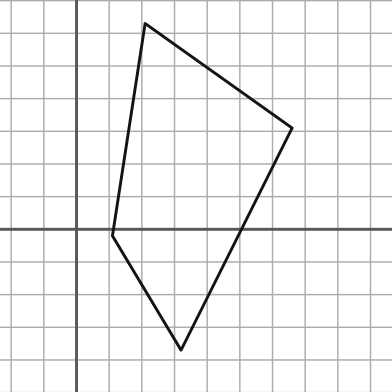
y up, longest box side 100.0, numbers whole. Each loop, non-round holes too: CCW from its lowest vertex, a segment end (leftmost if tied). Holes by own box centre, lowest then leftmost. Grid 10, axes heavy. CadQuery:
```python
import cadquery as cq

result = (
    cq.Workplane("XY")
    .moveTo(32.0, -37.0)
    .lineTo(66.0, 31.0)
    .lineTo(21.0, 63.0)
    .lineTo(11.0, -2.0)
    .close()
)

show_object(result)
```